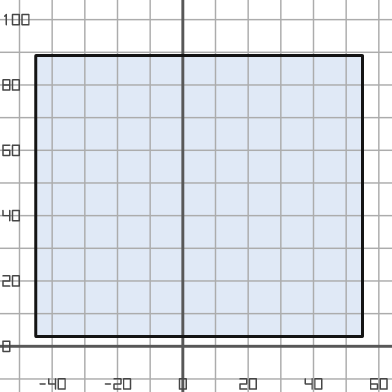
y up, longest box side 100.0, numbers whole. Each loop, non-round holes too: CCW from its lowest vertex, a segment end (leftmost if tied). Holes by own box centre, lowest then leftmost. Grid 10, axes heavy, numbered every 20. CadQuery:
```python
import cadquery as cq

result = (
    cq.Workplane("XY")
    .moveTo(-45.0, 3.0)
    .lineTo(55.0, 3.0)
    .lineTo(55.0, 89.0)
    .lineTo(-45.0, 89.0)
    .close()
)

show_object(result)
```